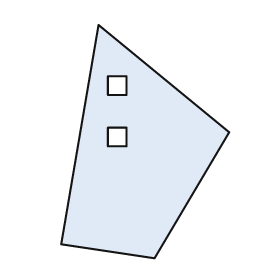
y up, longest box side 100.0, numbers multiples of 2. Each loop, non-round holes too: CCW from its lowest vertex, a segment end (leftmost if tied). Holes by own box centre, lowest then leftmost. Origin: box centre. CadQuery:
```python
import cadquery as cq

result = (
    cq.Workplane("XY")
    .moveTo(4.0, -50.0)
    .lineTo(36.0, 4.0)
    .lineTo(-20.0, 50.0)
    .lineTo(-36.0, -44.0)
    .close()
    .moveTo(-16.0, -2.0)
    .lineTo(-8.0, -2.0)
    .lineTo(-8.0, 6.0)
    .lineTo(-16.0, 6.0)
    .close()
    .moveTo(-16.0, 20.0)
    .lineTo(-8.0, 20.0)
    .lineTo(-8.0, 28.0)
    .lineTo(-16.0, 28.0)
    .close()
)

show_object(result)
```